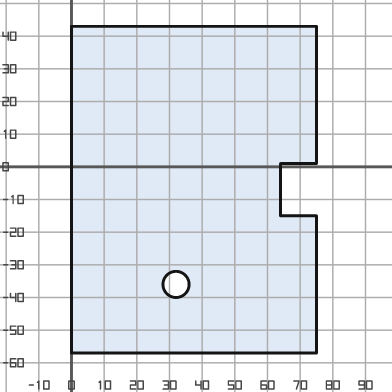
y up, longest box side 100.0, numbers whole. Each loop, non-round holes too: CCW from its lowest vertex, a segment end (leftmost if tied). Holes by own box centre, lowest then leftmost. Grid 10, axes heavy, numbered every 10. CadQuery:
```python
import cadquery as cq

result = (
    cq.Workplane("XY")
    .moveTo(0.0, -57.0)
    .lineTo(75.0, -57.0)
    .lineTo(75.0, -15.0)
    .lineTo(64.0, -15.0)
    .lineTo(64.0, 1.0)
    .lineTo(75.0, 1.0)
    .lineTo(75.0, 43.0)
    .lineTo(0.0, 43.0)
    .close()
    .moveTo(32.0, -36.0)
    .circle(4.0)
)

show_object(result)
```